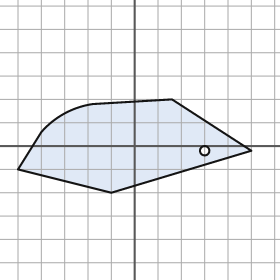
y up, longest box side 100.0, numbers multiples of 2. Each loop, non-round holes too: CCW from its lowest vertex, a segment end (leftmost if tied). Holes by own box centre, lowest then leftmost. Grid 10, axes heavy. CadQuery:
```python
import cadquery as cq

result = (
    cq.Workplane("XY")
    .moveTo(-10.0, -20.0)
    .lineTo(50.0, -2.0)
    .lineTo(16.0, 20.0)
    .lineTo(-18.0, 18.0)
    .threePointArc((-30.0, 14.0), (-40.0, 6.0))
    .lineTo(-50.0, -10.0)
    .close()
    .moveTo(30.0, -2.0)
    .circle(2.0)
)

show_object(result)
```